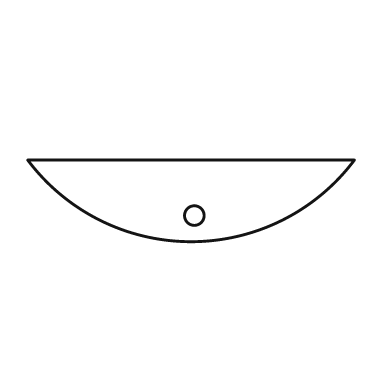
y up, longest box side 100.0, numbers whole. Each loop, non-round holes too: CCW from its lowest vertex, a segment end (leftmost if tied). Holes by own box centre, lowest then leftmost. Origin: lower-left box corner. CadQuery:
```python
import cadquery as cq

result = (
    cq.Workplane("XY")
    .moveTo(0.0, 25.0)
    .threePointArc((50.0, 0.0), (100.0, 25.0))
    .close()
    .moveTo(51.0, 8.0)
    .circle(3.0)
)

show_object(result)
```